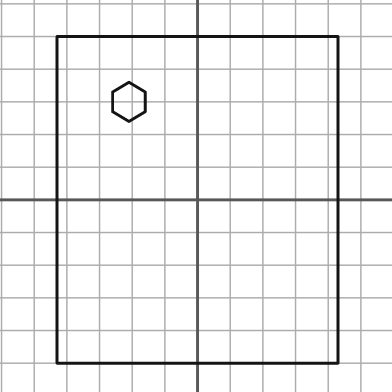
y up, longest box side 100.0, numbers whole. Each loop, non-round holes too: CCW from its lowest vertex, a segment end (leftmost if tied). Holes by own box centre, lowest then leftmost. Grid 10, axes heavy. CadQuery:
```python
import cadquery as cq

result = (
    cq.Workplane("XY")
    .moveTo(-43.0, -50.0)
    .lineTo(43.0, -50.0)
    .lineTo(43.0, 50.0)
    .lineTo(-43.0, 50.0)
    .close()
    .moveTo(-21.0, 24.0)
    .lineTo(-16.0, 27.0)
    .lineTo(-16.0, 33.0)
    .lineTo(-21.0, 36.0)
    .lineTo(-26.0, 33.0)
    .lineTo(-26.0, 27.0)
    .close()
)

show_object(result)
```